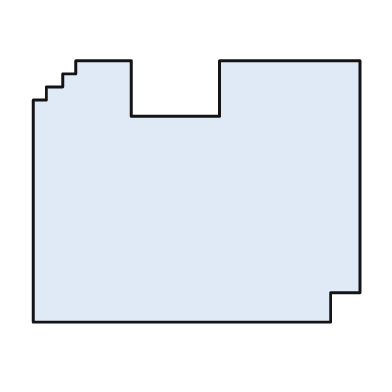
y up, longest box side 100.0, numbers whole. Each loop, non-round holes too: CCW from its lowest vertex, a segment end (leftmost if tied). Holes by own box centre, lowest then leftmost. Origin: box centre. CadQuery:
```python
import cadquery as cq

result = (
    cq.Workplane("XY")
    .moveTo(-50.0, -40.0)
    .lineTo(41.0, -40.0)
    .lineTo(41.0, -31.0)
    .lineTo(50.0, -31.0)
    .lineTo(50.0, 40.0)
    .lineTo(7.0, 40.0)
    .lineTo(7.0, 23.0)
    .lineTo(-20.0, 23.0)
    .lineTo(-20.0, 40.0)
    .lineTo(-37.0, 40.0)
    .lineTo(-37.0, 36.0)
    .lineTo(-41.0, 36.0)
    .lineTo(-41.0, 32.0)
    .lineTo(-46.0, 32.0)
    .lineTo(-46.0, 28.0)
    .lineTo(-50.0, 28.0)
    .close()
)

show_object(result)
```